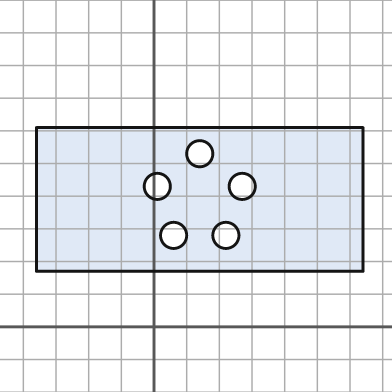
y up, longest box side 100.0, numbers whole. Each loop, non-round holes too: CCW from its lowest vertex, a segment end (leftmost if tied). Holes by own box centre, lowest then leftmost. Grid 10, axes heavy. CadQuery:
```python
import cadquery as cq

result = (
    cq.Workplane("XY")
    .moveTo(-36.0, 17.0)
    .lineTo(64.0, 17.0)
    .lineTo(64.0, 61.0)
    .lineTo(-36.0, 61.0)
    .close()
    .moveTo(6.0, 28.0)
    .circle(4.0)
    .moveTo(22.0, 28.0)
    .circle(4.0)
    .moveTo(1.0, 43.0)
    .circle(4.0)
    .moveTo(27.0, 43.0)
    .circle(4.0)
    .moveTo(14.0, 53.0)
    .circle(4.0)
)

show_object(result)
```